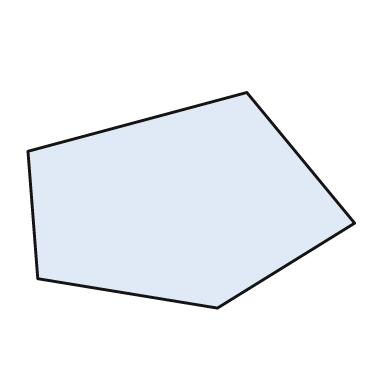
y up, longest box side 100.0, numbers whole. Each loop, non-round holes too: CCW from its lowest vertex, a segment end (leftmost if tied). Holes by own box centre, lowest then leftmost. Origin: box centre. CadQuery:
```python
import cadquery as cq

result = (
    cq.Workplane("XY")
    .moveTo(8.0, -33.0)
    .lineTo(50.0, -7.0)
    .lineTo(17.0, 33.0)
    .lineTo(-50.0, 15.0)
    .lineTo(-47.0, -24.0)
    .close()
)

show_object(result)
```